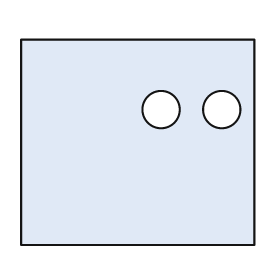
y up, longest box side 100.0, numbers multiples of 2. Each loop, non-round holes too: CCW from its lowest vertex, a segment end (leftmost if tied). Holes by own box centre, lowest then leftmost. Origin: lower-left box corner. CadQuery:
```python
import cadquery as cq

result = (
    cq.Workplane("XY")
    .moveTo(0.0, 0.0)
    .lineTo(100.0, 0.0)
    .lineTo(100.0, 88.0)
    .lineTo(0.0, 88.0)
    .close()
    .moveTo(60.0, 58.0)
    .circle(8.0)
    .moveTo(86.0, 58.0)
    .circle(8.0)
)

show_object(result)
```